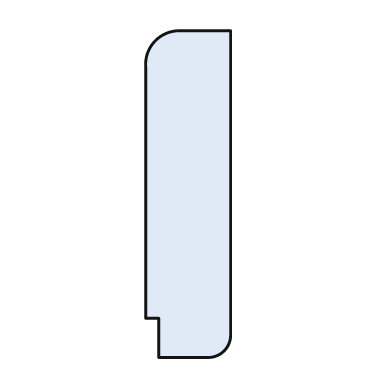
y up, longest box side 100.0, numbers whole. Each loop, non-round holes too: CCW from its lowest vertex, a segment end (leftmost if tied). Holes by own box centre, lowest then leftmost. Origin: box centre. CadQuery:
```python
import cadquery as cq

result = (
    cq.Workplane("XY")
    .moveTo(-9.0, -50.0)
    .lineTo(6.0, -50.0)
    .threePointArc((11.0, -48.0), (13.0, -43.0))
    .lineTo(13.0, 50.0)
    .lineTo(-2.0, 50.0)
    .threePointArc((-10.0, 47.0), (-13.0, 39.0))
    .lineTo(-13.0, -38.0)
    .lineTo(-9.0, -38.0)
    .close()
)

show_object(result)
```